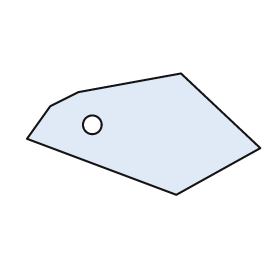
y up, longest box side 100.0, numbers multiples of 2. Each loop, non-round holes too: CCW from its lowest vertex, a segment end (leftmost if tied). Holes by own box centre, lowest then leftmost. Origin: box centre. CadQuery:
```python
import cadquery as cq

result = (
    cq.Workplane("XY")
    .moveTo(14.0, -26.0)
    .lineTo(50.0, -6.0)
    .lineTo(16.0, 26.0)
    .lineTo(-28.0, 18.0)
    .lineTo(-40.0, 12.0)
    .lineTo(-50.0, -2.0)
    .close()
    .moveTo(-22.0, 4.0)
    .circle(4.0)
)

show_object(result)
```